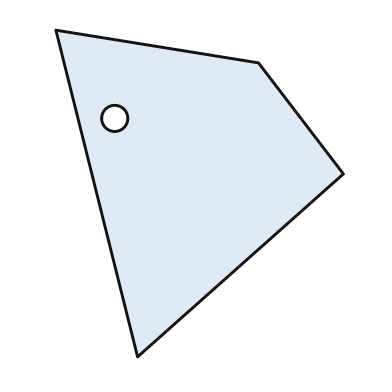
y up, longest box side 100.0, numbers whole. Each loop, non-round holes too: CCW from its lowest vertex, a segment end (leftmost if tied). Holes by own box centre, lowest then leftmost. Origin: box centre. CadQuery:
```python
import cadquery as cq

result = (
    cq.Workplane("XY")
    .moveTo(-19.0, -50.0)
    .lineTo(44.0, 6.0)
    .lineTo(18.0, 40.0)
    .lineTo(-44.0, 50.0)
    .close()
    .moveTo(-26.0, 23.0)
    .circle(4.0)
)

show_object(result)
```